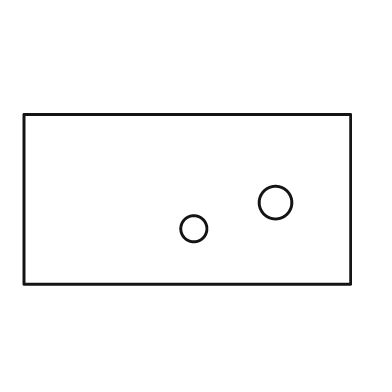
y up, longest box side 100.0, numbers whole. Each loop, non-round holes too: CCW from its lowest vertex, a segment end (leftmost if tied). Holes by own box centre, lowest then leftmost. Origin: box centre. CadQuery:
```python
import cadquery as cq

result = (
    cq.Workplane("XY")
    .moveTo(-50.0, -26.0)
    .lineTo(50.0, -26.0)
    .lineTo(50.0, 26.0)
    .lineTo(-50.0, 26.0)
    .close()
    .moveTo(2.0, -9.0)
    .circle(4.0)
    .moveTo(27.0, -1.0)
    .circle(5.0)
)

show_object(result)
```